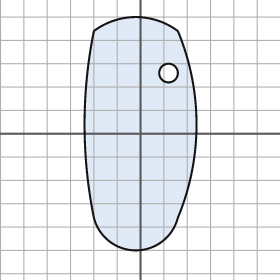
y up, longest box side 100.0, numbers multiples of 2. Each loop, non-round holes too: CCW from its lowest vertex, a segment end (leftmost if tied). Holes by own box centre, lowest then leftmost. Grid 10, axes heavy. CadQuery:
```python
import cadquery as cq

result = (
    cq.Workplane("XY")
    .moveTo(-20.0, -36.0)
    .threePointArc((-2.0, -50.0), (16.0, -36.0))
    .threePointArc((24.0, 4.0), (16.0, 44.0))
    .threePointArc((-2.0, 50.0), (-20.0, 44.0))
    .threePointArc((-24.0, 4.0), (-20.0, -36.0))
    .close()
    .moveTo(12.0, 26.0)
    .circle(4.0)
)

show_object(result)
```